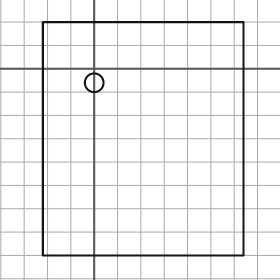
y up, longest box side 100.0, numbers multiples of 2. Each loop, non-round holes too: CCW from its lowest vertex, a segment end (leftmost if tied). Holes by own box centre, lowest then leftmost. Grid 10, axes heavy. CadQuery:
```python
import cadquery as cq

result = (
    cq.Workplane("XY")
    .moveTo(-22.0, -80.0)
    .lineTo(64.0, -80.0)
    .lineTo(64.0, 20.0)
    .lineTo(-22.0, 20.0)
    .close()
    .moveTo(0.0, -6.0)
    .circle(4.0)
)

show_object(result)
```